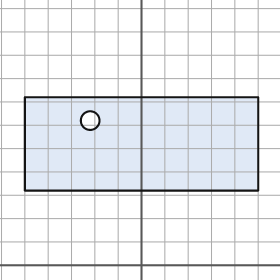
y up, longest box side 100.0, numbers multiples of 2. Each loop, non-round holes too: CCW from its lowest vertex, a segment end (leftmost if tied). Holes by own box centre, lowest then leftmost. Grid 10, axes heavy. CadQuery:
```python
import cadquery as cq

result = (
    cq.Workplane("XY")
    .moveTo(-50.0, 32.0)
    .lineTo(50.0, 32.0)
    .lineTo(50.0, 72.0)
    .lineTo(-50.0, 72.0)
    .close()
    .moveTo(-22.0, 62.0)
    .circle(4.0)
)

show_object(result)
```